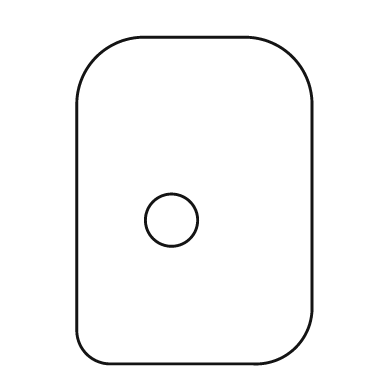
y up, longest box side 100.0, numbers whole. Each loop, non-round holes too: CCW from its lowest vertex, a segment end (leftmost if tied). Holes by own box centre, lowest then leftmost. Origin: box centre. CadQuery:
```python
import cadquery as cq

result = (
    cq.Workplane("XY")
    .moveTo(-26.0, -50.0)
    .lineTo(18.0, -50.0)
    .threePointArc((31.0, -45.0), (36.0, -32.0))
    .lineTo(36.0, 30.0)
    .threePointArc((30.0, 44.0), (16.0, 50.0))
    .lineTo(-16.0, 50.0)
    .threePointArc((-30.0, 44.0), (-36.0, 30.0))
    .lineTo(-36.0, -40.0)
    .threePointArc((-33.0, -47.0), (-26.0, -50.0))
    .close()
    .moveTo(-7.0, -6.0)
    .circle(8.0)
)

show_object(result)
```